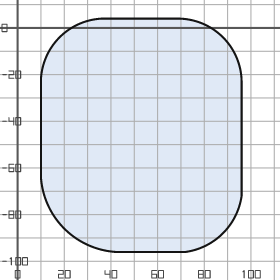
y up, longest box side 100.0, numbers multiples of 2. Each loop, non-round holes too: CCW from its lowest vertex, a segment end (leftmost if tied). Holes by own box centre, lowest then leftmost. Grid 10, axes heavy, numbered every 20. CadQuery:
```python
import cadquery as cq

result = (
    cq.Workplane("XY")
    .moveTo(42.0, -96.0)
    .lineTo(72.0, -96.0)
    .threePointArc((88.0, -88.0), (96.0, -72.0))
    .lineTo(96.0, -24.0)
    .threePointArc((88.0, -4.0), (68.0, 4.0))
    .lineTo(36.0, 4.0)
    .threePointArc((18.0, -4.0), (10.0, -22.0))
    .lineTo(10.0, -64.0)
    .threePointArc((20.0, -86.0), (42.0, -96.0))
    .close()
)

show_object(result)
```